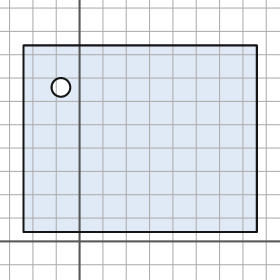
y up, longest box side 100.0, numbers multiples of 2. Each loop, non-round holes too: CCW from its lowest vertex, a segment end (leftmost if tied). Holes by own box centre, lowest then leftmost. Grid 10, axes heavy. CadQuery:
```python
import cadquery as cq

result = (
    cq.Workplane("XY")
    .moveTo(-24.0, 4.0)
    .lineTo(76.0, 4.0)
    .lineTo(76.0, 84.0)
    .lineTo(-24.0, 84.0)
    .close()
    .moveTo(-8.0, 66.0)
    .circle(4.0)
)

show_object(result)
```